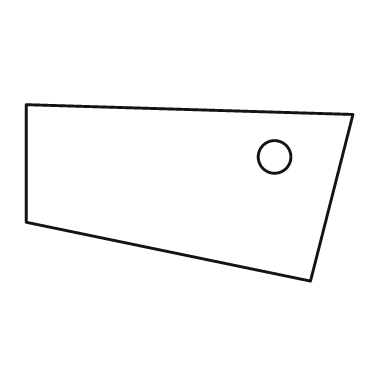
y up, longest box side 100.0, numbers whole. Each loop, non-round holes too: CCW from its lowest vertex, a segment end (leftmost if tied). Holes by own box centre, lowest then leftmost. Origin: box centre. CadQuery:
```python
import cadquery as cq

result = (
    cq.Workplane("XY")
    .moveTo(37.0, -27.0)
    .lineTo(50.0, 24.0)
    .lineTo(-50.0, 27.0)
    .lineTo(-50.0, -9.0)
    .close()
    .moveTo(26.0, 11.0)
    .circle(5.0)
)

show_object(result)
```